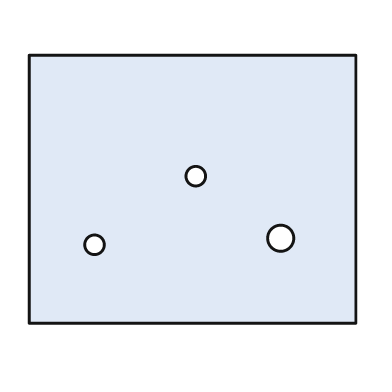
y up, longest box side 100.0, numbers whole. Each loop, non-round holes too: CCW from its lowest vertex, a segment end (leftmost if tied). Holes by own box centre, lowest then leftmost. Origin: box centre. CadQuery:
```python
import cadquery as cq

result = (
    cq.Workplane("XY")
    .moveTo(-50.0, -41.0)
    .lineTo(50.0, -41.0)
    .lineTo(50.0, 41.0)
    .lineTo(-50.0, 41.0)
    .close()
    .moveTo(-30.0, -17.0)
    .circle(3.0)
    .moveTo(27.0, -15.0)
    .circle(4.0)
    .moveTo(1.0, 4.0)
    .circle(3.0)
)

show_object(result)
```